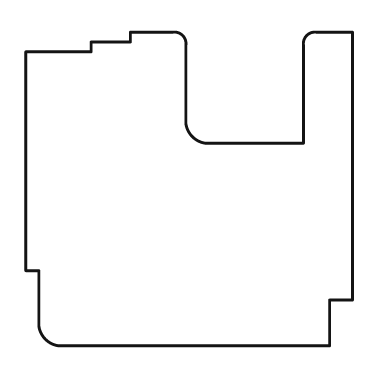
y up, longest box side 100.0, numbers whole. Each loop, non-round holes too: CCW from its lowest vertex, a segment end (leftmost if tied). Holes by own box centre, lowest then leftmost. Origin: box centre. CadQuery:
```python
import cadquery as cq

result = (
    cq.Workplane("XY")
    .moveTo(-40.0, -48.0)
    .lineTo(43.0, -48.0)
    .lineTo(43.0, -34.0)
    .lineTo(50.0, -34.0)
    .lineTo(50.0, 48.0)
    .lineTo(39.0, 48.0)
    .threePointArc((36.0, 47.0), (35.0, 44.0))
    .lineTo(35.0, 14.0)
    .lineTo(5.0, 14.0)
    .threePointArc((1.0, 16.0), (-1.0, 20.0))
    .lineTo(-1.0, 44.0)
    .threePointArc((-2.0, 47.0), (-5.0, 48.0))
    .lineTo(-18.0, 48.0)
    .lineTo(-18.0, 45.0)
    .lineTo(-30.0, 45.0)
    .lineTo(-30.0, 42.0)
    .lineTo(-50.0, 42.0)
    .lineTo(-50.0, -25.0)
    .lineTo(-46.0, -25.0)
    .lineTo(-46.0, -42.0)
    .threePointArc((-44.0, -46.0), (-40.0, -48.0))
    .close()
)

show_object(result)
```